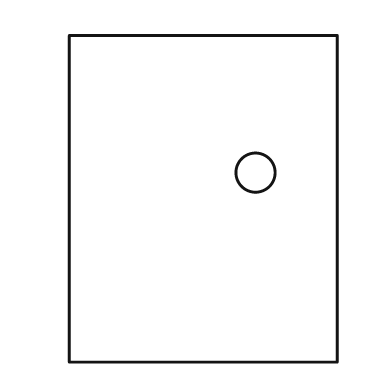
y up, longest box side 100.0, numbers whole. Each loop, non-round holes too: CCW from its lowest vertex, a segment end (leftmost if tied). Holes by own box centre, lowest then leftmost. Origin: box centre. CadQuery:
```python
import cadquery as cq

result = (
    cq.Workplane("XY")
    .moveTo(-41.0, -50.0)
    .lineTo(41.0, -50.0)
    .lineTo(41.0, 50.0)
    .lineTo(-41.0, 50.0)
    .close()
    .moveTo(16.0, 8.0)
    .circle(6.0)
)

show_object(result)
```